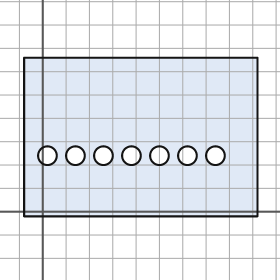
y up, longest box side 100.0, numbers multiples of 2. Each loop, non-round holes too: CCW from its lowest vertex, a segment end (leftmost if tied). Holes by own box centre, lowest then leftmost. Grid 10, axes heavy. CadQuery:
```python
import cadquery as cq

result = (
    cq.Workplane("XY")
    .moveTo(-8.0, -2.0)
    .lineTo(92.0, -2.0)
    .lineTo(92.0, 66.0)
    .lineTo(-8.0, 66.0)
    .close()
    .moveTo(2.0, 24.0)
    .circle(4.0)
    .moveTo(14.0, 24.0)
    .circle(4.0)
    .moveTo(26.0, 24.0)
    .circle(4.0)
    .moveTo(38.0, 24.0)
    .circle(4.0)
    .moveTo(50.0, 24.0)
    .circle(4.0)
    .moveTo(62.0, 24.0)
    .circle(4.0)
    .moveTo(74.0, 24.0)
    .circle(4.0)
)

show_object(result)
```